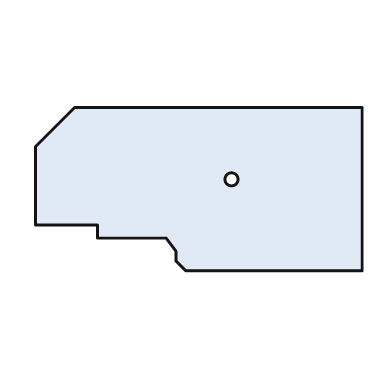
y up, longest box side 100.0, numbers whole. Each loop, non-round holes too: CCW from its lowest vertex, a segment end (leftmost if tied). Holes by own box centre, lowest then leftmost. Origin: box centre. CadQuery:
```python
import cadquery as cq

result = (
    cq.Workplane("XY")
    .moveTo(-4.0, -25.0)
    .lineTo(50.0, -25.0)
    .lineTo(50.0, 25.0)
    .lineTo(-38.0, 25.0)
    .lineTo(-50.0, 13.0)
    .lineTo(-50.0, -11.0)
    .lineTo(-31.0, -11.0)
    .lineTo(-31.0, -15.0)
    .lineTo(-10.0, -15.0)
    .lineTo(-7.0, -19.0)
    .lineTo(-7.0, -22.0)
    .close()
    .moveTo(10.0, 3.0)
    .circle(2.0)
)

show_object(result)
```